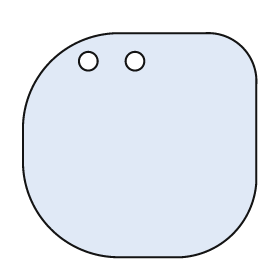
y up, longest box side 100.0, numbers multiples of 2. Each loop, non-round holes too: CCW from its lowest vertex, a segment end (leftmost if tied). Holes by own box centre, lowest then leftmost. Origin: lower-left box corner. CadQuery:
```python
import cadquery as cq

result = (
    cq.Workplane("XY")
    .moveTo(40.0, 0.0)
    .lineTo(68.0, 0.0)
    .threePointArc((90.0, 10.0), (100.0, 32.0))
    .lineTo(100.0, 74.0)
    .threePointArc((94.0, 90.0), (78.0, 96.0))
    .lineTo(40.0, 96.0)
    .threePointArc((12.0, 84.0), (0.0, 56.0))
    .lineTo(0.0, 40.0)
    .threePointArc((12.0, 12.0), (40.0, 0.0))
    .close()
    .moveTo(28.0, 84.0)
    .circle(4.0)
    .moveTo(48.0, 84.0)
    .circle(4.0)
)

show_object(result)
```